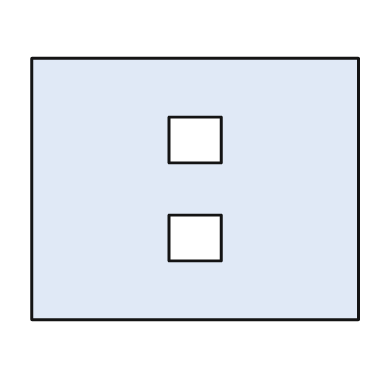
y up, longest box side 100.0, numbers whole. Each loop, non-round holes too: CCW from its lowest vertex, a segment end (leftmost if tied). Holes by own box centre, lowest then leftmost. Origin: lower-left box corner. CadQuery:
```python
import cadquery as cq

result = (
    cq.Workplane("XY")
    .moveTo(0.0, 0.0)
    .lineTo(100.0, 0.0)
    .lineTo(100.0, 80.0)
    .lineTo(0.0, 80.0)
    .close()
    .moveTo(42.0, 18.0)
    .lineTo(58.0, 18.0)
    .lineTo(58.0, 32.0)
    .lineTo(42.0, 32.0)
    .close()
    .moveTo(42.0, 48.0)
    .lineTo(58.0, 48.0)
    .lineTo(58.0, 62.0)
    .lineTo(42.0, 62.0)
    .close()
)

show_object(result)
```